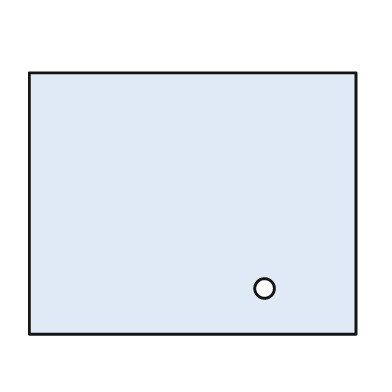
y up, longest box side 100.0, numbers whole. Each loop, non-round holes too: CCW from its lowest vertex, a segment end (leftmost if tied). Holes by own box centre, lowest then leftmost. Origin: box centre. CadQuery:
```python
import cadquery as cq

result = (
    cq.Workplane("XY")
    .moveTo(-50.0, -40.0)
    .lineTo(50.0, -40.0)
    .lineTo(50.0, 40.0)
    .lineTo(-50.0, 40.0)
    .close()
    .moveTo(22.0, -26.0)
    .circle(3.0)
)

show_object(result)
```